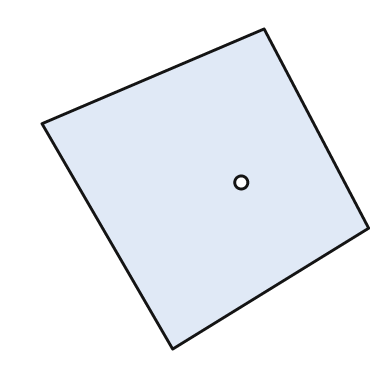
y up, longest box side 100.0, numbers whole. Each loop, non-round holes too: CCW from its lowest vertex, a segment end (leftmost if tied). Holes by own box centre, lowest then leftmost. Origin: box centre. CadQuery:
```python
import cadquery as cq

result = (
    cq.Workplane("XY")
    .moveTo(-10.0, -49.0)
    .lineTo(50.0, -12.0)
    .lineTo(18.0, 49.0)
    .lineTo(-50.0, 20.0)
    .close()
    .moveTo(11.0, 2.0)
    .circle(2.0)
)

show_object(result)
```